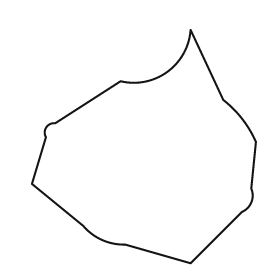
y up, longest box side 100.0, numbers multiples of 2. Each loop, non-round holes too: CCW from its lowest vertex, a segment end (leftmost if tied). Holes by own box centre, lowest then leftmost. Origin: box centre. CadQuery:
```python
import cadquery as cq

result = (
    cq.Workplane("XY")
    .moveTo(20.0, -50.0)
    .lineTo(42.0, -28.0)
    .threePointArc((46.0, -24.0), (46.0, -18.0))
    .lineTo(48.0, 2.0)
    .threePointArc((42.0, 12.0), (34.0, 20.0))
    .lineTo(20.0, 50.0)
    .threePointArc((10.0, 32.0), (-10.0, 28.0))
    .lineTo(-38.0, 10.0)
    .threePointArc((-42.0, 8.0), (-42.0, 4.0))
    .lineTo(-48.0, -16.0)
    .lineTo(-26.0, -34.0)
    .threePointArc((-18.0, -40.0), (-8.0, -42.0))
    .close()
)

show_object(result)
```